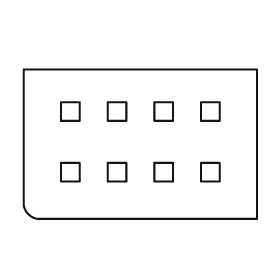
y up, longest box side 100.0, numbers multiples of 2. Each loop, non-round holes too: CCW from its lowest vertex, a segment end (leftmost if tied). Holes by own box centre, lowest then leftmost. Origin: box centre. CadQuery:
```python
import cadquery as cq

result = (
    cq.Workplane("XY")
    .moveTo(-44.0, -32.0)
    .lineTo(50.0, -32.0)
    .lineTo(50.0, 32.0)
    .lineTo(-50.0, 32.0)
    .lineTo(-50.0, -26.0)
    .threePointArc((-48.0, -30.0), (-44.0, -32.0))
    .close()
    .moveTo(-34.0, -16.0)
    .lineTo(-26.0, -16.0)
    .lineTo(-26.0, -8.0)
    .lineTo(-34.0, -8.0)
    .close()
    .moveTo(-14.0, -16.0)
    .lineTo(-6.0, -16.0)
    .lineTo(-6.0, -8.0)
    .lineTo(-14.0, -8.0)
    .close()
    .moveTo(6.0, -16.0)
    .lineTo(14.0, -16.0)
    .lineTo(14.0, -8.0)
    .lineTo(6.0, -8.0)
    .close()
    .moveTo(26.0, -16.0)
    .lineTo(34.0, -16.0)
    .lineTo(34.0, -8.0)
    .lineTo(26.0, -8.0)
    .close()
    .moveTo(-34.0, 10.0)
    .lineTo(-26.0, 10.0)
    .lineTo(-26.0, 18.0)
    .lineTo(-34.0, 18.0)
    .close()
    .moveTo(-14.0, 10.0)
    .lineTo(-6.0, 10.0)
    .lineTo(-6.0, 18.0)
    .lineTo(-14.0, 18.0)
    .close()
    .moveTo(6.0, 10.0)
    .lineTo(14.0, 10.0)
    .lineTo(14.0, 18.0)
    .lineTo(6.0, 18.0)
    .close()
    .moveTo(26.0, 10.0)
    .lineTo(34.0, 10.0)
    .lineTo(34.0, 18.0)
    .lineTo(26.0, 18.0)
    .close()
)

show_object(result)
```